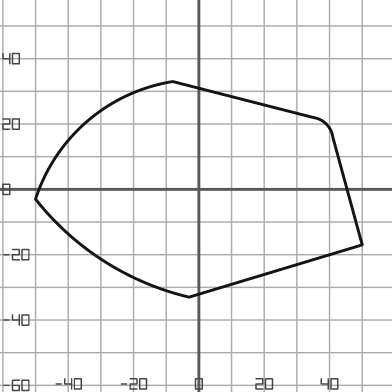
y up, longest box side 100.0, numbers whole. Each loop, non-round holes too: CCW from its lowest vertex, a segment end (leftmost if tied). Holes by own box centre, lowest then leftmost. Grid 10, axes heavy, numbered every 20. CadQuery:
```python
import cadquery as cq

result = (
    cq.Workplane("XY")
    .moveTo(-3.0, -33.0)
    .lineTo(50.0, -17.0)
    .lineTo(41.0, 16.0)
    .threePointArc((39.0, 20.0), (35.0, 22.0))
    .lineTo(-8.0, 33.0)
    .threePointArc((-34.0, 21.0), (-50.0, -3.0))
    .threePointArc((-29.0, -22.0), (-3.0, -33.0))
    .close()
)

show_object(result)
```